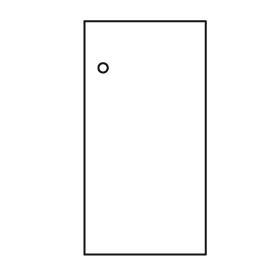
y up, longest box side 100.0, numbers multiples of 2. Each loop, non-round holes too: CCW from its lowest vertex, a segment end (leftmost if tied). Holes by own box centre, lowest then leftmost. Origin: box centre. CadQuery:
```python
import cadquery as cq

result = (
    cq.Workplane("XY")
    .moveTo(-26.0, -50.0)
    .lineTo(26.0, -50.0)
    .lineTo(26.0, 50.0)
    .lineTo(-26.0, 50.0)
    .close()
    .moveTo(-18.0, 30.0)
    .circle(2.0)
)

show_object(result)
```